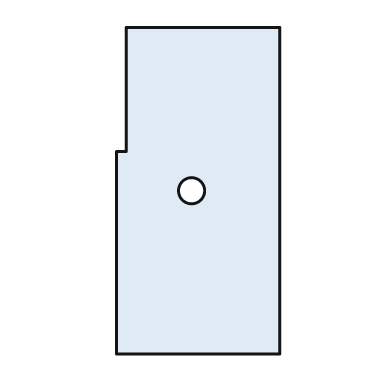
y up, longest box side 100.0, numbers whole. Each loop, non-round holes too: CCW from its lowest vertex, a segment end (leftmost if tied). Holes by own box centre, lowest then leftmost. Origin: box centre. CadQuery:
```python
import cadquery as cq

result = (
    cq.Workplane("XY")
    .moveTo(-25.0, -50.0)
    .lineTo(25.0, -50.0)
    .lineTo(25.0, 50.0)
    .lineTo(-22.0, 50.0)
    .lineTo(-22.0, 12.0)
    .lineTo(-25.0, 12.0)
    .close()
    .moveTo(-2.0, 0.0)
    .circle(4.0)
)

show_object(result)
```